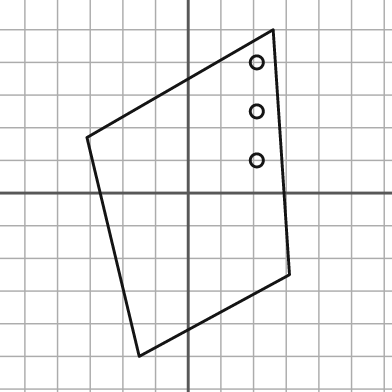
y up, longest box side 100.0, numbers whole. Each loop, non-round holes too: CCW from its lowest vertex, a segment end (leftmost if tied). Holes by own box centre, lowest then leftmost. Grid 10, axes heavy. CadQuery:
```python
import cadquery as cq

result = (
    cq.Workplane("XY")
    .moveTo(-15.0, -50.0)
    .lineTo(31.0, -25.0)
    .lineTo(26.0, 50.0)
    .lineTo(-31.0, 17.0)
    .close()
    .moveTo(21.0, 10.0)
    .circle(2.0)
    .moveTo(21.0, 25.0)
    .circle(2.0)
    .moveTo(21.0, 40.0)
    .circle(2.0)
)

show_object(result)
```